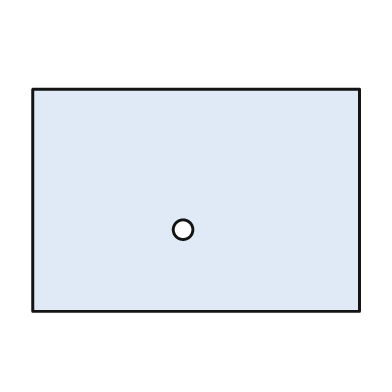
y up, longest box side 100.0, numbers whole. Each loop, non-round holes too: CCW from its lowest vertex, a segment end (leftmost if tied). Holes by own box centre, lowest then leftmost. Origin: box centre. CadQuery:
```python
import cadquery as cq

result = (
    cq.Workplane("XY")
    .moveTo(-50.0, -34.0)
    .lineTo(50.0, -34.0)
    .lineTo(50.0, 34.0)
    .lineTo(-50.0, 34.0)
    .close()
    .moveTo(-4.0, -9.0)
    .circle(3.0)
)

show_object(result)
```